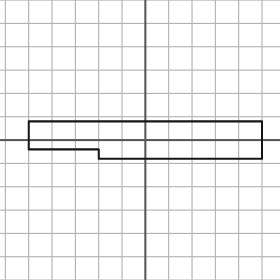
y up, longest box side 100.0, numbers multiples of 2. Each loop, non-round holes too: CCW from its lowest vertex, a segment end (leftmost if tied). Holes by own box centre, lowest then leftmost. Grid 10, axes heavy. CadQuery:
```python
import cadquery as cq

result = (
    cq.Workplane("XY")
    .moveTo(-20.0, -8.0)
    .lineTo(50.0, -8.0)
    .lineTo(50.0, 8.0)
    .lineTo(-50.0, 8.0)
    .lineTo(-50.0, -4.0)
    .lineTo(-20.0, -4.0)
    .close()
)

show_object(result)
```